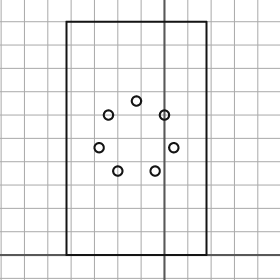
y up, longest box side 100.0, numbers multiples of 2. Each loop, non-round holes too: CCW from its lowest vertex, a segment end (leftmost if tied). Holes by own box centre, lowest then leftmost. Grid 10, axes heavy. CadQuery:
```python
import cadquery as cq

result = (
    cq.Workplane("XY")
    .moveTo(-42.0, 0.0)
    .lineTo(18.0, 0.0)
    .lineTo(18.0, 100.0)
    .lineTo(-42.0, 100.0)
    .close()
    .moveTo(-20.0, 36.0)
    .circle(2.0)
    .moveTo(-4.0, 36.0)
    .circle(2.0)
    .moveTo(-28.0, 46.0)
    .circle(2.0)
    .moveTo(4.0, 46.0)
    .circle(2.0)
    .moveTo(-24.0, 60.0)
    .circle(2.0)
    .moveTo(0.0, 60.0)
    .circle(2.0)
    .moveTo(-12.0, 66.0)
    .circle(2.0)
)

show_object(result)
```